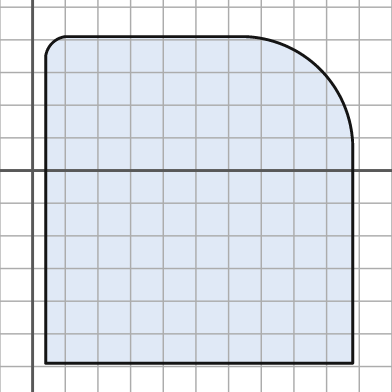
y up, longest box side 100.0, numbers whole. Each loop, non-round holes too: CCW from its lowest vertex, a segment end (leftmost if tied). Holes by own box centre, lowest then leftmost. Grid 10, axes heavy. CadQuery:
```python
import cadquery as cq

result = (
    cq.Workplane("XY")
    .moveTo(4.0, -59.0)
    .lineTo(98.0, -59.0)
    .lineTo(98.0, 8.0)
    .threePointArc((88.0, 31.0), (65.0, 41.0))
    .lineTo(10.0, 41.0)
    .threePointArc((6.0, 39.0), (4.0, 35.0))
    .close()
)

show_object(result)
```